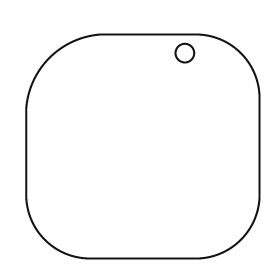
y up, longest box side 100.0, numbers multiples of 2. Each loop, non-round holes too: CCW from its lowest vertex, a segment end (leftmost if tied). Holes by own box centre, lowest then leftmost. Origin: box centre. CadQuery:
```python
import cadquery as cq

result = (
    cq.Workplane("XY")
    .moveTo(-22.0, -48.0)
    .lineTo(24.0, -48.0)
    .threePointArc((42.0, -40.0), (50.0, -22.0))
    .lineTo(50.0, 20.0)
    .threePointArc((42.0, 40.0), (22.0, 48.0))
    .lineTo(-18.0, 48.0)
    .threePointArc((-40.0, 38.0), (-50.0, 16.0))
    .lineTo(-50.0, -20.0)
    .threePointArc((-42.0, -40.0), (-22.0, -48.0))
    .close()
    .moveTo(18.0, 40.0)
    .circle(4.0)
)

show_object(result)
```